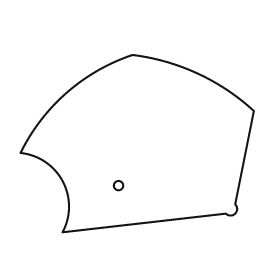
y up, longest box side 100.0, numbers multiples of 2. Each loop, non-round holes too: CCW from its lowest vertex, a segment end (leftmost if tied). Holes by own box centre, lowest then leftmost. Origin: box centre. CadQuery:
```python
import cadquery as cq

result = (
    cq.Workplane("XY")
    .moveTo(-32.0, -38.0)
    .lineTo(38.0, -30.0)
    .threePointArc((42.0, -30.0), (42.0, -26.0))
    .lineTo(50.0, 14.0)
    .threePointArc((26.0, 30.0), (-2.0, 38.0))
    .threePointArc((-30.0, 22.0), (-50.0, -4.0))
    .threePointArc((-32.0, -16.0), (-32.0, -38.0))
    .close()
    .moveTo(-8.0, -18.0)
    .circle(2.0)
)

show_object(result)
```